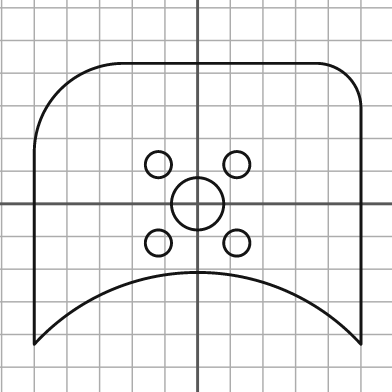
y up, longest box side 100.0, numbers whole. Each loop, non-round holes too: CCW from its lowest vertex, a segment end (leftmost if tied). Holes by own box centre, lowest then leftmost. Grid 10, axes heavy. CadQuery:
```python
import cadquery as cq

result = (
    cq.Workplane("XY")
    .moveTo(-50.0, -43.0)
    .threePointArc((0.0, -21.0), (50.0, -43.0))
    .lineTo(50.0, 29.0)
    .threePointArc((46.0, 39.0), (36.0, 43.0))
    .lineTo(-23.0, 43.0)
    .threePointArc((-42.0, 35.0), (-50.0, 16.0))
    .close()
    .moveTo(-12.0, -12.0)
    .circle(4.0)
    .moveTo(12.0, -12.0)
    .circle(4.0)
    .moveTo(0.0, 0.0)
    .circle(8.0)
    .moveTo(-12.0, 12.0)
    .circle(4.0)
    .moveTo(12.0, 12.0)
    .circle(4.0)
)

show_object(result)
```